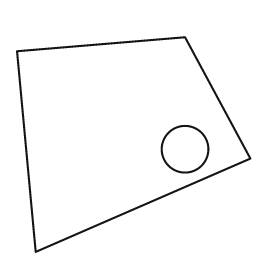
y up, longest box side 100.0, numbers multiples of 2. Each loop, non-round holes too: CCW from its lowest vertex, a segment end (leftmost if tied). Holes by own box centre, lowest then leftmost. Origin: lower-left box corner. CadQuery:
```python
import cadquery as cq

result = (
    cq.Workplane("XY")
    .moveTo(8.0, 0.0)
    .lineTo(100.0, 40.0)
    .lineTo(72.0, 92.0)
    .lineTo(0.0, 86.0)
    .close()
    .moveTo(72.0, 44.0)
    .circle(10.0)
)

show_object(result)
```